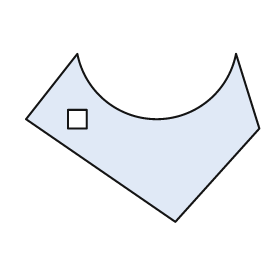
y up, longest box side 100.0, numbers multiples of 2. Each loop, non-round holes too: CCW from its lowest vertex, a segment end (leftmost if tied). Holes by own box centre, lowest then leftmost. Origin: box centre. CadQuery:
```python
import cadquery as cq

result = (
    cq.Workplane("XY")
    .moveTo(14.0, -36.0)
    .lineTo(50.0, 4.0)
    .lineTo(40.0, 36.0)
    .threePointArc((6.0, 8.0), (-28.0, 36.0))
    .lineTo(-50.0, 8.0)
    .close()
    .moveTo(-32.0, 4.0)
    .lineTo(-24.0, 4.0)
    .lineTo(-24.0, 12.0)
    .lineTo(-32.0, 12.0)
    .close()
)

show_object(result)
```